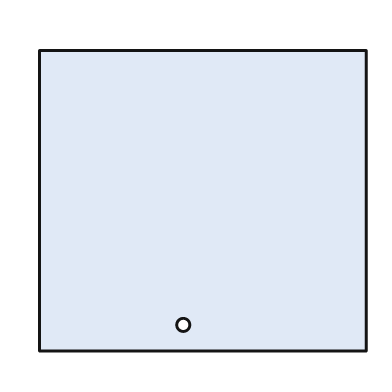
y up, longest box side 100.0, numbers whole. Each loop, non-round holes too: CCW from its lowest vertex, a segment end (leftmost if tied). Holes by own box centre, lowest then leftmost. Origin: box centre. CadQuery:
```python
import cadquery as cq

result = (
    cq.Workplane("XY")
    .moveTo(-50.0, -46.0)
    .lineTo(50.0, -46.0)
    .lineTo(50.0, 46.0)
    .lineTo(-50.0, 46.0)
    .close()
    .moveTo(-6.0, -38.0)
    .circle(2.0)
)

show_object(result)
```